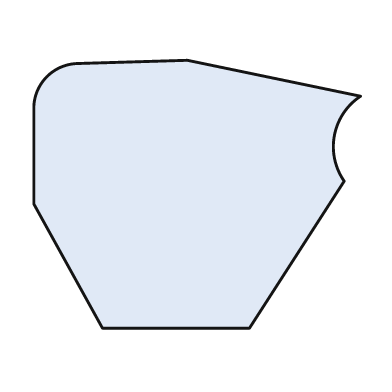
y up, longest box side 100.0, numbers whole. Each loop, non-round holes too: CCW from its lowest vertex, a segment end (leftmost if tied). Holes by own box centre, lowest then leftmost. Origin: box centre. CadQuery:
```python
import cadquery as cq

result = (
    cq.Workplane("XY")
    .moveTo(-29.0, -41.0)
    .lineTo(16.0, -41.0)
    .lineTo(45.0, 4.0)
    .threePointArc((42.0, 18.0), (50.0, 30.0))
    .lineTo(-3.0, 41.0)
    .lineTo(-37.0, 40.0)
    .threePointArc((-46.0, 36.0), (-50.0, 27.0))
    .lineTo(-50.0, -3.0)
    .close()
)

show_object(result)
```